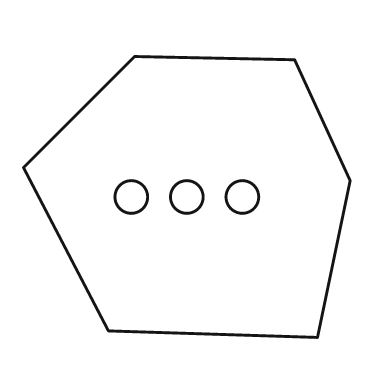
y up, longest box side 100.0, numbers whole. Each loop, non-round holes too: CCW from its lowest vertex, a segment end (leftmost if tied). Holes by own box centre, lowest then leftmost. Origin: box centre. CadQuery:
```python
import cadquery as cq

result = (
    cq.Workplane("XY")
    .moveTo(40.0, -43.0)
    .lineTo(50.0, 5.0)
    .lineTo(33.0, 42.0)
    .lineTo(-16.0, 43.0)
    .lineTo(-50.0, 9.0)
    .lineTo(-24.0, -41.0)
    .close()
    .moveTo(-17.0, 0.0)
    .circle(5.0)
    .moveTo(0.0, 0.0)
    .circle(5.0)
    .moveTo(17.0, 0.0)
    .circle(5.0)
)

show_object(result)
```